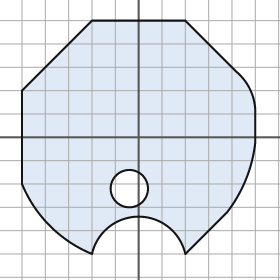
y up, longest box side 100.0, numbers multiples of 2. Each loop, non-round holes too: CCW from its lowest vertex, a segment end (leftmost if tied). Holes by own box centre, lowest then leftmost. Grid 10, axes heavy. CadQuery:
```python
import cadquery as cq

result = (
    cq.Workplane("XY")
    .moveTo(-20.0, -50.0)
    .threePointArc((0.0, -34.0), (20.0, -50.0))
    .lineTo(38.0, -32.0)
    .threePointArc((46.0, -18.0), (50.0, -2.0))
    .lineTo(50.0, 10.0)
    .threePointArc((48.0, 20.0), (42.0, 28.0))
    .lineTo(20.0, 50.0)
    .lineTo(-20.0, 50.0)
    .lineTo(-50.0, 20.0)
    .lineTo(-50.0, -20.0)
    .threePointArc((-38.0, -38.0), (-20.0, -50.0))
    .close()
    .moveTo(-4.0, -22.0)
    .circle(8.0)
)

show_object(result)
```